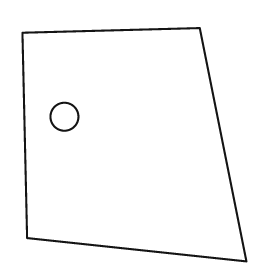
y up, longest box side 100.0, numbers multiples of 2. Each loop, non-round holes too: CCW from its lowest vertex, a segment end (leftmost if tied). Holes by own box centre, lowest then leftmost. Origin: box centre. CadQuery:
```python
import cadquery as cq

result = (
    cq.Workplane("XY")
    .moveTo(48.0, -50.0)
    .lineTo(28.0, 50.0)
    .lineTo(-48.0, 48.0)
    .lineTo(-46.0, -40.0)
    .close()
    .moveTo(-30.0, 12.0)
    .circle(6.0)
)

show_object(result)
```